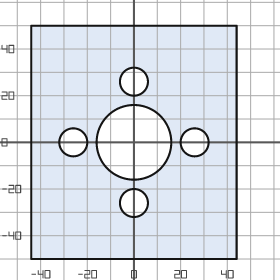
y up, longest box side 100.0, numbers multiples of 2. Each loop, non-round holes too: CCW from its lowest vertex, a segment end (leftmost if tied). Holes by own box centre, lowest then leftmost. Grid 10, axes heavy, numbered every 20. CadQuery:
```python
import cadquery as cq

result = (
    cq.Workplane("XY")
    .moveTo(-44.0, -50.0)
    .lineTo(44.0, -50.0)
    .lineTo(44.0, 50.0)
    .lineTo(-44.0, 50.0)
    .close()
    .moveTo(0.0, -26.0)
    .circle(6.0)
    .moveTo(-26.0, 0.0)
    .circle(6.0)
    .moveTo(0.0, 0.0)
    .circle(16.0)
    .moveTo(26.0, 0.0)
    .circle(6.0)
    .moveTo(0.0, 26.0)
    .circle(6.0)
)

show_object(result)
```